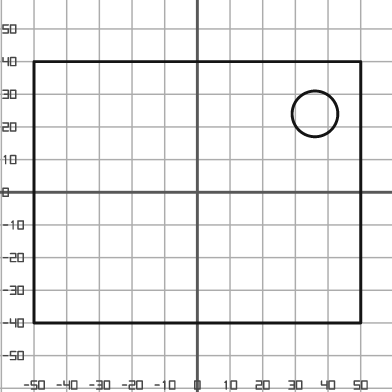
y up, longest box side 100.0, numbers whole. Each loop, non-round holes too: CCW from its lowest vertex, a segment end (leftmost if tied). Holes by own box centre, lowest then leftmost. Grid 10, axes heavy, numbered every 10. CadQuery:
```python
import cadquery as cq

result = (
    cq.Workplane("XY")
    .moveTo(-50.0, -40.0)
    .lineTo(50.0, -40.0)
    .lineTo(50.0, 40.0)
    .lineTo(-50.0, 40.0)
    .close()
    .moveTo(36.0, 24.0)
    .circle(7.0)
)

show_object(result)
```